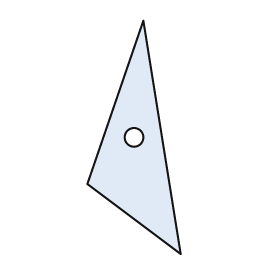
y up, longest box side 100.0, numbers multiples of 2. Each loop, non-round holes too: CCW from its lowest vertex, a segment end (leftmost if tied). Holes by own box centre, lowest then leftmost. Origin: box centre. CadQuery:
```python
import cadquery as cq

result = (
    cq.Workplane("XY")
    .moveTo(20.0, -50.0)
    .lineTo(4.0, 50.0)
    .lineTo(-20.0, -20.0)
    .close()
    .moveTo(0.0, 0.0)
    .circle(4.0)
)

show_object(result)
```